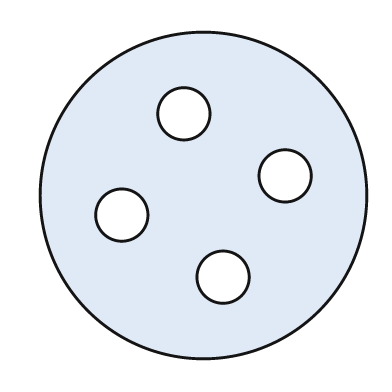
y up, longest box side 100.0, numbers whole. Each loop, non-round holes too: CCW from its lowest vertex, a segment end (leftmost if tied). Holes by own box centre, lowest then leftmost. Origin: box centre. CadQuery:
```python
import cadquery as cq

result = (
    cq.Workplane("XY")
    .moveTo(0.0, 0.0)
    .circle(50.0)
    .moveTo(6.0, -25.0)
    .circle(8.0)
    .moveTo(-25.0, -6.0)
    .circle(8.0)
    .moveTo(25.0, 6.0)
    .circle(8.0)
    .moveTo(-6.0, 25.0)
    .circle(8.0)
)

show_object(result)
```